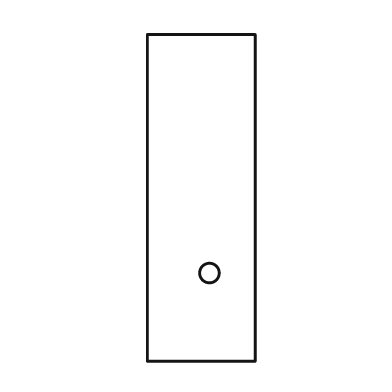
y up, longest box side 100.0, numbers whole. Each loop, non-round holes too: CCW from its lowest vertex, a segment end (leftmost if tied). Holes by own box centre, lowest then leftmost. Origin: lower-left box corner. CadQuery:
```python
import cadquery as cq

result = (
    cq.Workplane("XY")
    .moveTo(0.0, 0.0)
    .lineTo(33.0, 0.0)
    .lineTo(33.0, 100.0)
    .lineTo(0.0, 100.0)
    .close()
    .moveTo(19.0, 27.0)
    .circle(3.0)
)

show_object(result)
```